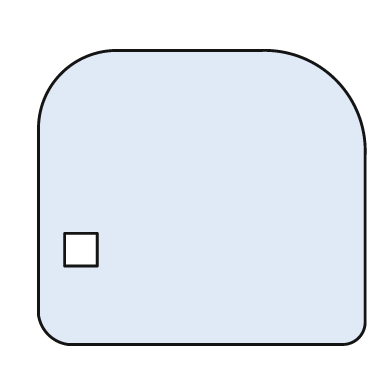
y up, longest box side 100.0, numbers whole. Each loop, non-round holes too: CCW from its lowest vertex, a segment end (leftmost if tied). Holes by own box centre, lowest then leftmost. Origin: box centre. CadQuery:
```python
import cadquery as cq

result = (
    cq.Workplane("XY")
    .moveTo(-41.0, -45.0)
    .lineTo(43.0, -45.0)
    .threePointArc((48.0, -43.0), (50.0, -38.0))
    .lineTo(50.0, 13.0)
    .threePointArc((41.0, 36.0), (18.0, 45.0))
    .lineTo(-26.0, 45.0)
    .threePointArc((-43.0, 38.0), (-50.0, 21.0))
    .lineTo(-50.0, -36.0)
    .threePointArc((-47.0, -42.0), (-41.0, -45.0))
    .close()
    .moveTo(-42.0, -21.0)
    .lineTo(-32.0, -21.0)
    .lineTo(-32.0, -11.0)
    .lineTo(-42.0, -11.0)
    .close()
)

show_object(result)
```